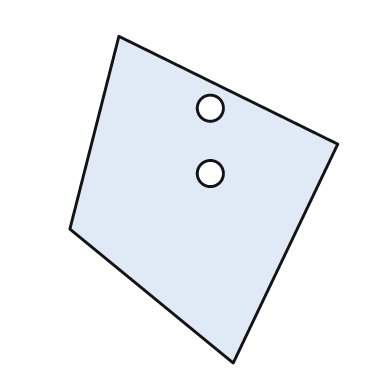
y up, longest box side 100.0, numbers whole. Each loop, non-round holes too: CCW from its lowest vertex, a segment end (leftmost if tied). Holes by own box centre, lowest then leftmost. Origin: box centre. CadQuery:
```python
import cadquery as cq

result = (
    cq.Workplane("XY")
    .moveTo(9.0, -50.0)
    .lineTo(41.0, 17.0)
    .lineTo(-26.0, 50.0)
    .lineTo(-41.0, -9.0)
    .close()
    .moveTo(2.0, 8.0)
    .circle(4.0)
    .moveTo(2.0, 28.0)
    .circle(4.0)
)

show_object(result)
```